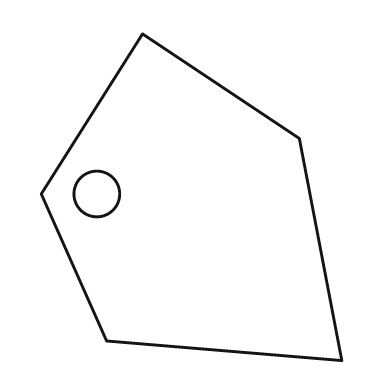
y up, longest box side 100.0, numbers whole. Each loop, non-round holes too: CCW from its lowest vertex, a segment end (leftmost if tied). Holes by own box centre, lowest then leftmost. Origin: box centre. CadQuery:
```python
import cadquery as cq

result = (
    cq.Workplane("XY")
    .moveTo(46.0, -50.0)
    .lineTo(33.0, 18.0)
    .lineTo(-15.0, 50.0)
    .lineTo(-46.0, 1.0)
    .lineTo(-26.0, -44.0)
    .close()
    .moveTo(-29.0, 1.0)
    .circle(7.0)
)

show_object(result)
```